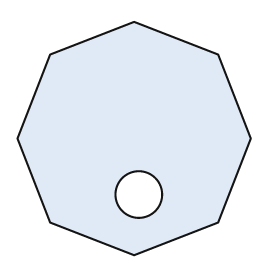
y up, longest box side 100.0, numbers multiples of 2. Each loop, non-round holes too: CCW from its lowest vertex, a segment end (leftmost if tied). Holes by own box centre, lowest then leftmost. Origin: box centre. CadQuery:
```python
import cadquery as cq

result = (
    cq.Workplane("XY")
    .moveTo(0.0, -50.0)
    .lineTo(36.0, -36.0)
    .lineTo(50.0, 0.0)
    .lineTo(36.0, 36.0)
    .lineTo(0.0, 50.0)
    .lineTo(-36.0, 36.0)
    .lineTo(-50.0, 0.0)
    .lineTo(-36.0, -36.0)
    .close()
    .moveTo(2.0, -24.0)
    .circle(10.0)
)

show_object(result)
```